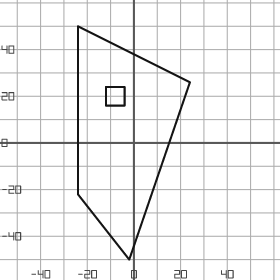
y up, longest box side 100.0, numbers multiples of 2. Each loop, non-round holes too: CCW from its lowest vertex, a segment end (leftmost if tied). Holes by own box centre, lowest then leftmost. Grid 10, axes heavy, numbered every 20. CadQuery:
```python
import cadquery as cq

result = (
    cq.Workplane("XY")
    .moveTo(-2.0, -50.0)
    .lineTo(24.0, 26.0)
    .lineTo(-24.0, 50.0)
    .lineTo(-24.0, -22.0)
    .close()
    .moveTo(-12.0, 16.0)
    .lineTo(-4.0, 16.0)
    .lineTo(-4.0, 24.0)
    .lineTo(-12.0, 24.0)
    .close()
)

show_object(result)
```